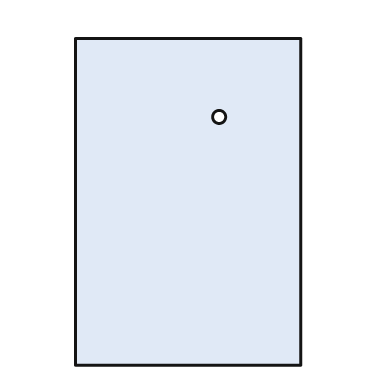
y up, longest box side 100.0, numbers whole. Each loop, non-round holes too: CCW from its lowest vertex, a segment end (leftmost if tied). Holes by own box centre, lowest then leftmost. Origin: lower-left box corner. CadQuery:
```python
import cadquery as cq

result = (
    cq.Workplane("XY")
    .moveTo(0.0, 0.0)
    .lineTo(69.0, 0.0)
    .lineTo(69.0, 100.0)
    .lineTo(0.0, 100.0)
    .close()
    .moveTo(44.0, 76.0)
    .circle(2.0)
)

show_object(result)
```